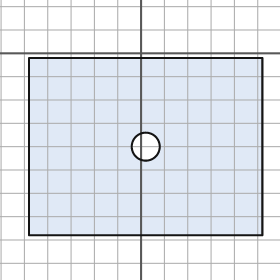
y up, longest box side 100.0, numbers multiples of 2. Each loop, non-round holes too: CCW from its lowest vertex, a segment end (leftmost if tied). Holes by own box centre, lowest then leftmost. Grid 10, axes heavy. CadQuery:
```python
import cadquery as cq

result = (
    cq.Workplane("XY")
    .moveTo(-48.0, -78.0)
    .lineTo(52.0, -78.0)
    .lineTo(52.0, -2.0)
    .lineTo(-48.0, -2.0)
    .close()
    .moveTo(2.0, -40.0)
    .circle(6.0)
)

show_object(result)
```